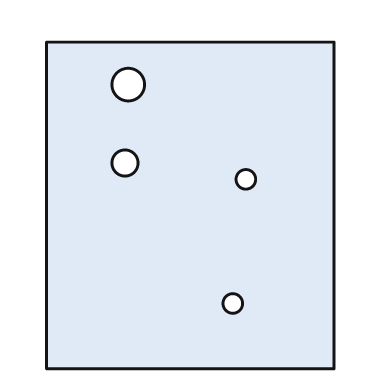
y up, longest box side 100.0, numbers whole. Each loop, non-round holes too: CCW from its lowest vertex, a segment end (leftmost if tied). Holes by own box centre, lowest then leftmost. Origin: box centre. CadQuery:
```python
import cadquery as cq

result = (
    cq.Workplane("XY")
    .moveTo(-44.0, -50.0)
    .lineTo(44.0, -50.0)
    .lineTo(44.0, 50.0)
    .lineTo(-44.0, 50.0)
    .close()
    .moveTo(13.0, -30.0)
    .circle(3.0)
    .moveTo(17.0, 8.0)
    .circle(3.0)
    .moveTo(-20.0, 13.0)
    .circle(4.0)
    .moveTo(-19.0, 37.0)
    .circle(5.0)
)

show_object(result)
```